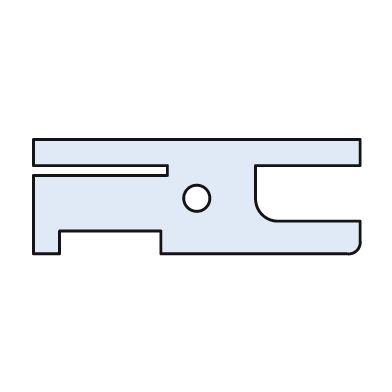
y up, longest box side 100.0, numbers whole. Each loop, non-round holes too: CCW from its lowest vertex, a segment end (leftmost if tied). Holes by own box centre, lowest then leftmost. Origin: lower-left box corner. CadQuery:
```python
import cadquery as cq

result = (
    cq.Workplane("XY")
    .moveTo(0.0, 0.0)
    .lineTo(8.0, 0.0)
    .lineTo(8.0, 7.0)
    .lineTo(39.0, 7.0)
    .lineTo(39.0, 0.0)
    .lineTo(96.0, 0.0)
    .threePointArc((99.0, 1.0), (100.0, 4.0))
    .lineTo(100.0, 10.0)
    .lineTo(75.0, 10.0)
    .threePointArc((70.0, 12.0), (68.0, 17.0))
    .lineTo(68.0, 27.0)
    .lineTo(100.0, 27.0)
    .lineTo(100.0, 35.0)
    .lineTo(0.0, 35.0)
    .lineTo(0.0, 27.0)
    .lineTo(41.0, 27.0)
    .lineTo(41.0, 24.0)
    .lineTo(0.0, 24.0)
    .close()
    .moveTo(50.0, 17.0)
    .circle(4.0)
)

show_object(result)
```